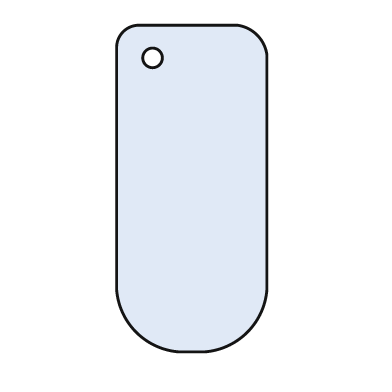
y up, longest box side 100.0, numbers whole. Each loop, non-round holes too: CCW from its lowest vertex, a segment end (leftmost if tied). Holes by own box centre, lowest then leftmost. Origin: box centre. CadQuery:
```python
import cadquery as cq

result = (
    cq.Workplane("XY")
    .moveTo(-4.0, -50.0)
    .lineTo(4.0, -50.0)
    .threePointArc((17.0, -44.0), (23.0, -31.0))
    .lineTo(23.0, 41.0)
    .threePointArc((20.0, 47.0), (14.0, 50.0))
    .lineTo(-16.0, 50.0)
    .threePointArc((-21.0, 48.0), (-23.0, 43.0))
    .lineTo(-23.0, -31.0)
    .threePointArc((-17.0, -44.0), (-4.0, -50.0))
    .close()
    .moveTo(-12.0, 40.0)
    .circle(3.0)
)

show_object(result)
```